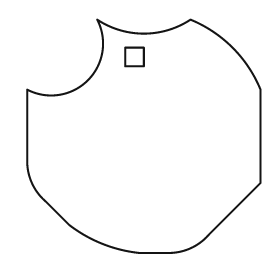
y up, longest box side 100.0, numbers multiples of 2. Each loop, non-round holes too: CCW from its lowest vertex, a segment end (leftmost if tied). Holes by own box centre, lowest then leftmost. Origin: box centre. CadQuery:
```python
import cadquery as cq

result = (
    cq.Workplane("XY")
    .moveTo(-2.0, -50.0)
    .lineTo(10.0, -50.0)
    .threePointArc((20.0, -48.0), (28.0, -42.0))
    .lineTo(50.0, -20.0)
    .lineTo(50.0, 20.0)
    .threePointArc((38.0, 38.0), (20.0, 50.0))
    .threePointArc((0.0, 44.0), (-20.0, 50.0))
    .threePointArc((-24.0, 24.0), (-50.0, 20.0))
    .lineTo(-50.0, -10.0)
    .threePointArc((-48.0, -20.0), (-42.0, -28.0))
    .lineTo(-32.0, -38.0)
    .threePointArc((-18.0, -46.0), (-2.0, -50.0))
    .close()
    .moveTo(-8.0, 30.0)
    .lineTo(0.0, 30.0)
    .lineTo(0.0, 38.0)
    .lineTo(-8.0, 38.0)
    .close()
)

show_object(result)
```